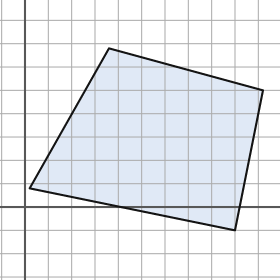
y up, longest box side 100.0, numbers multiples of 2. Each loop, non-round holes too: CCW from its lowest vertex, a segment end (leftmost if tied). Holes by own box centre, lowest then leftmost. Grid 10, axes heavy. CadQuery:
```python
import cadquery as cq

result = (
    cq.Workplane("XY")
    .moveTo(90.0, -10.0)
    .lineTo(102.0, 50.0)
    .lineTo(36.0, 68.0)
    .lineTo(2.0, 8.0)
    .close()
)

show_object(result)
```